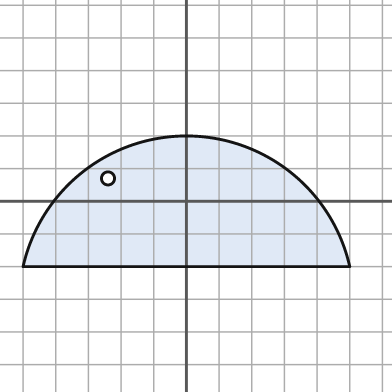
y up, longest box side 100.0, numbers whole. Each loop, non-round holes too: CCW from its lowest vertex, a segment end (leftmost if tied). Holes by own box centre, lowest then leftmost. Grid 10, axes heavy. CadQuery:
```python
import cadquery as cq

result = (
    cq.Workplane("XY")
    .moveTo(-50.0, -20.0)
    .lineTo(50.0, -20.0)
    .threePointArc((0.0, 20.0), (-50.0, -20.0))
    .close()
    .moveTo(-24.0, 7.0)
    .circle(2.0)
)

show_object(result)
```